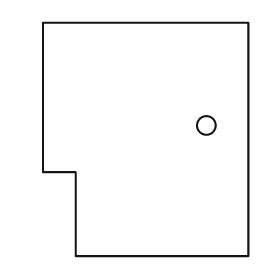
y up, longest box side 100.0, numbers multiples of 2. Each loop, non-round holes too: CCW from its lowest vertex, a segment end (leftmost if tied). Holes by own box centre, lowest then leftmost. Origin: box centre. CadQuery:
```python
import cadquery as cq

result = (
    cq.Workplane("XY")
    .moveTo(-30.0, -50.0)
    .lineTo(44.0, -50.0)
    .lineTo(44.0, 50.0)
    .lineTo(-44.0, 50.0)
    .lineTo(-44.0, -14.0)
    .lineTo(-30.0, -14.0)
    .close()
    .moveTo(26.0, 6.0)
    .circle(4.0)
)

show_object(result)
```